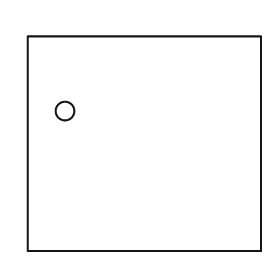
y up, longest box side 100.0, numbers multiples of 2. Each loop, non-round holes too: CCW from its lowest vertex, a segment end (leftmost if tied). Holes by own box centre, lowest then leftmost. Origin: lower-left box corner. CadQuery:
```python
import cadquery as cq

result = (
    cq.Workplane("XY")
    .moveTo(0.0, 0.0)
    .lineTo(100.0, 0.0)
    .lineTo(100.0, 92.0)
    .lineTo(0.0, 92.0)
    .close()
    .moveTo(16.0, 60.0)
    .circle(4.0)
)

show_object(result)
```